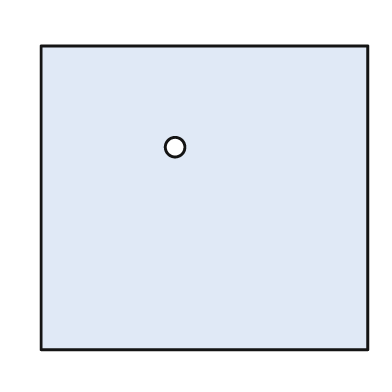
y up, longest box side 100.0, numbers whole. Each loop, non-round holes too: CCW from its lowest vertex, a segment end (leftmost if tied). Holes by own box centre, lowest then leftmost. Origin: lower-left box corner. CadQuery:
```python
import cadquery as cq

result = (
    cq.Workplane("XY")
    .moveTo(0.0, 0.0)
    .lineTo(100.0, 0.0)
    .lineTo(100.0, 93.0)
    .lineTo(0.0, 93.0)
    .close()
    .moveTo(41.0, 62.0)
    .circle(3.0)
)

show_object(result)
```